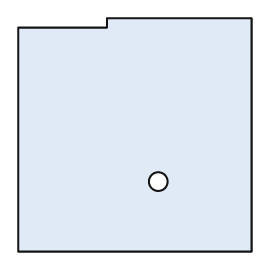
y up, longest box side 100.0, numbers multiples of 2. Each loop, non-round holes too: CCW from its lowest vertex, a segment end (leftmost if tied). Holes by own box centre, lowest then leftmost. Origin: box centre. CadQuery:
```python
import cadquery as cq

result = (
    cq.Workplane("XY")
    .moveTo(-50.0, -50.0)
    .lineTo(50.0, -50.0)
    .lineTo(50.0, 50.0)
    .lineTo(-12.0, 50.0)
    .lineTo(-12.0, 46.0)
    .lineTo(-50.0, 46.0)
    .close()
    .moveTo(10.0, -20.0)
    .circle(4.0)
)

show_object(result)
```